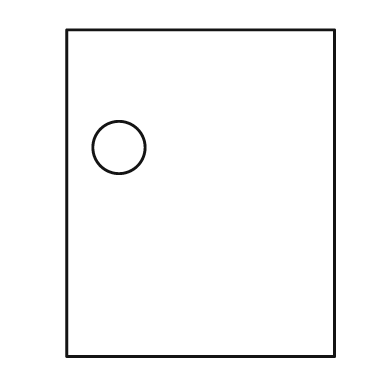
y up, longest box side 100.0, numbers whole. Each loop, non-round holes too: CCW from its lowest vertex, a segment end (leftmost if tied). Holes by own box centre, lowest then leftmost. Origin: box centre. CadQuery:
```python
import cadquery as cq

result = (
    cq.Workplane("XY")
    .moveTo(-41.0, -50.0)
    .lineTo(41.0, -50.0)
    .lineTo(41.0, 50.0)
    .lineTo(-41.0, 50.0)
    .close()
    .moveTo(-25.0, 14.0)
    .circle(8.0)
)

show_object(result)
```